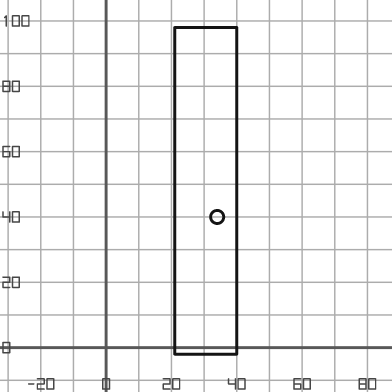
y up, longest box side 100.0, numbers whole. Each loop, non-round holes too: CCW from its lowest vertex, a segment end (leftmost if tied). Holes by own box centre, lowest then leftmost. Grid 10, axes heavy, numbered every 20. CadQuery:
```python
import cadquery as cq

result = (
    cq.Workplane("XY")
    .moveTo(21.0, -2.0)
    .lineTo(40.0, -2.0)
    .lineTo(40.0, 98.0)
    .lineTo(21.0, 98.0)
    .close()
    .moveTo(34.0, 40.0)
    .circle(2.0)
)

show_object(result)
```